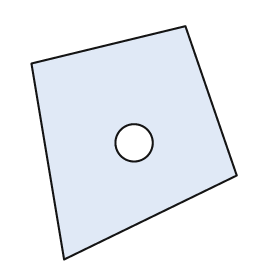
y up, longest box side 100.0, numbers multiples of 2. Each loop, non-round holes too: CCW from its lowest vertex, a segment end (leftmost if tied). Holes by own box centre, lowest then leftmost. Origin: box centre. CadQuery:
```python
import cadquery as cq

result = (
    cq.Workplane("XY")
    .moveTo(-30.0, -50.0)
    .lineTo(44.0, -14.0)
    .lineTo(22.0, 50.0)
    .lineTo(-44.0, 34.0)
    .close()
    .moveTo(0.0, 0.0)
    .circle(8.0)
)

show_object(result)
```